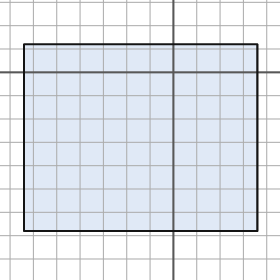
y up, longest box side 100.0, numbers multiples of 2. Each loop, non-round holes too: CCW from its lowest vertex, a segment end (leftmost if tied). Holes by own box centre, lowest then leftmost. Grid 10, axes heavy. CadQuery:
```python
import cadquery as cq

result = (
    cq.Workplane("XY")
    .moveTo(-64.0, -68.0)
    .lineTo(36.0, -68.0)
    .lineTo(36.0, 12.0)
    .lineTo(-64.0, 12.0)
    .close()
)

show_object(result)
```